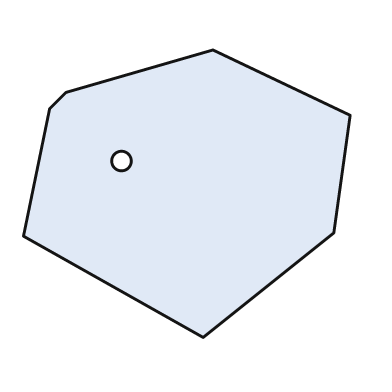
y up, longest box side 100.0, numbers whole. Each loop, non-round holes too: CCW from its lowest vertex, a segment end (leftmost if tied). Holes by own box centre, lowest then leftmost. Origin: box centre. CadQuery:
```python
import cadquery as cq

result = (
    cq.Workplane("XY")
    .moveTo(5.0, -44.0)
    .lineTo(45.0, -12.0)
    .lineTo(50.0, 24.0)
    .lineTo(8.0, 44.0)
    .lineTo(-37.0, 31.0)
    .lineTo(-42.0, 26.0)
    .lineTo(-50.0, -13.0)
    .close()
    .moveTo(-20.0, 10.0)
    .circle(3.0)
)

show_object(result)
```